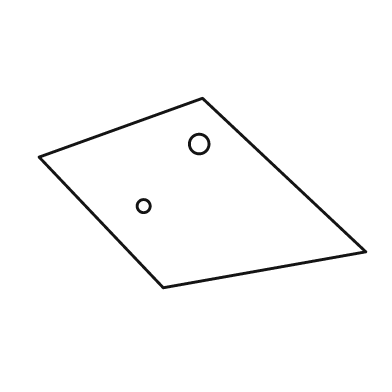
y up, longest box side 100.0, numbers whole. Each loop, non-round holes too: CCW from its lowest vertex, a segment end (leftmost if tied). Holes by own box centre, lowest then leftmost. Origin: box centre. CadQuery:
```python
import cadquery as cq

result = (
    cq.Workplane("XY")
    .moveTo(-12.0, -29.0)
    .lineTo(50.0, -18.0)
    .lineTo(0.0, 29.0)
    .lineTo(-50.0, 11.0)
    .close()
    .moveTo(-18.0, -4.0)
    .circle(2.0)
    .moveTo(-1.0, 15.0)
    .circle(3.0)
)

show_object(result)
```